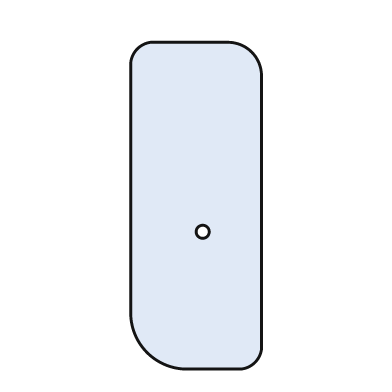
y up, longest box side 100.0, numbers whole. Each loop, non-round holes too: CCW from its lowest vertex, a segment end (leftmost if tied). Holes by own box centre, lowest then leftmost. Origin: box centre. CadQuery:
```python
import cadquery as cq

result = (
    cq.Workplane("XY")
    .moveTo(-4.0, -50.0)
    .lineTo(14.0, -50.0)
    .threePointArc((18.0, -48.0), (20.0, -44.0))
    .lineTo(20.0, 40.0)
    .threePointArc((17.0, 47.0), (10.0, 50.0))
    .lineTo(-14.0, 50.0)
    .threePointArc((-18.0, 48.0), (-20.0, 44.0))
    .lineTo(-20.0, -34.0)
    .threePointArc((-15.0, -45.0), (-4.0, -50.0))
    .close()
    .moveTo(2.0, -8.0)
    .circle(2.0)
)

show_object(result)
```